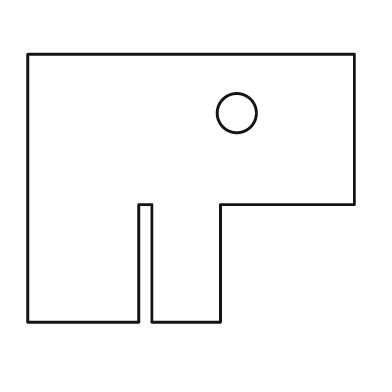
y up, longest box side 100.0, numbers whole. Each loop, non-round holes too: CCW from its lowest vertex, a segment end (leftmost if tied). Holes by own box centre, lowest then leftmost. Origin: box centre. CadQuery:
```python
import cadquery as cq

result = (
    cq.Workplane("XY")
    .moveTo(-50.0, -41.0)
    .lineTo(-16.0, -41.0)
    .lineTo(-16.0, -5.0)
    .lineTo(-12.0, -5.0)
    .lineTo(-12.0, -41.0)
    .lineTo(9.0, -41.0)
    .lineTo(9.0, -5.0)
    .lineTo(50.0, -5.0)
    .lineTo(50.0, 41.0)
    .lineTo(-50.0, 41.0)
    .close()
    .moveTo(14.0, 23.0)
    .circle(6.0)
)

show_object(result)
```